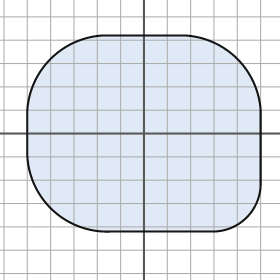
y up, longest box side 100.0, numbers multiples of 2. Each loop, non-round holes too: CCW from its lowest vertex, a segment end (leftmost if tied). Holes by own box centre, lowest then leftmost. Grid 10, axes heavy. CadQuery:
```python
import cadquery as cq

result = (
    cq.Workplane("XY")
    .moveTo(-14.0, -42.0)
    .lineTo(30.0, -42.0)
    .threePointArc((44.0, -36.0), (50.0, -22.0))
    .lineTo(50.0, 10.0)
    .threePointArc((40.0, 32.0), (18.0, 42.0))
    .lineTo(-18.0, 42.0)
    .threePointArc((-40.0, 32.0), (-50.0, 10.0))
    .lineTo(-50.0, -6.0)
    .threePointArc((-40.0, -32.0), (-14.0, -42.0))
    .close()
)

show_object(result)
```